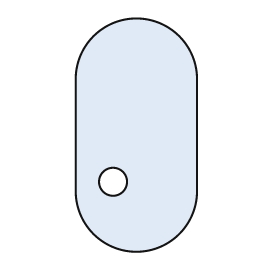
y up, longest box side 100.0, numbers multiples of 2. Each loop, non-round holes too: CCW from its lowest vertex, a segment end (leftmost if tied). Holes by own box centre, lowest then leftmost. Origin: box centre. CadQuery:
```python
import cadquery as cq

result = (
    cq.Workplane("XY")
    .moveTo(-26.0, -24.0)
    .threePointArc((0.0, -50.0), (26.0, -24.0))
    .lineTo(26.0, 24.0)
    .threePointArc((0.0, 50.0), (-26.0, 24.0))
    .close()
    .moveTo(-10.0, -20.0)
    .circle(6.0)
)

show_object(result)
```